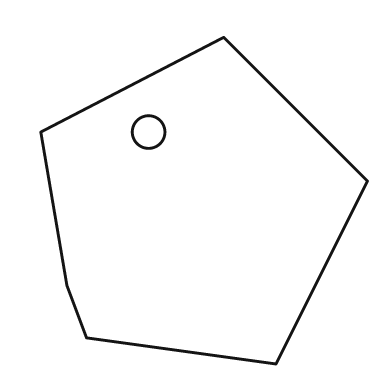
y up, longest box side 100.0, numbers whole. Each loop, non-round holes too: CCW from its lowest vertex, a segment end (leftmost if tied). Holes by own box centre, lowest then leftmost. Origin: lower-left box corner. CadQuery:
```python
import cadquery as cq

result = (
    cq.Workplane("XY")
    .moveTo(72.0, 0.0)
    .lineTo(100.0, 56.0)
    .lineTo(56.0, 100.0)
    .lineTo(0.0, 71.0)
    .lineTo(8.0, 24.0)
    .lineTo(14.0, 8.0)
    .close()
    .moveTo(33.0, 71.0)
    .circle(5.0)
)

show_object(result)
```